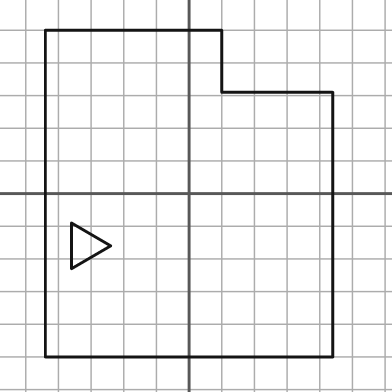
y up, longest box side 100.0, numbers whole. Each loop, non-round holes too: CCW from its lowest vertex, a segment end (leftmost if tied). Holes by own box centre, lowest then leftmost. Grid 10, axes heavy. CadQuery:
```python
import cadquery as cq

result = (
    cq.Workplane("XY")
    .moveTo(-44.0, -50.0)
    .lineTo(44.0, -50.0)
    .lineTo(44.0, 31.0)
    .lineTo(10.0, 31.0)
    .lineTo(10.0, 50.0)
    .lineTo(-44.0, 50.0)
    .close()
    .moveTo(-36.0, -23.0)
    .lineTo(-24.0, -16.0)
    .lineTo(-36.0, -9.0)
    .close()
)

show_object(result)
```